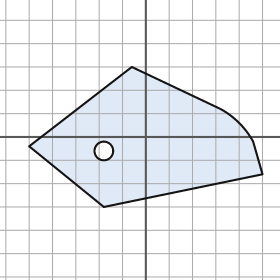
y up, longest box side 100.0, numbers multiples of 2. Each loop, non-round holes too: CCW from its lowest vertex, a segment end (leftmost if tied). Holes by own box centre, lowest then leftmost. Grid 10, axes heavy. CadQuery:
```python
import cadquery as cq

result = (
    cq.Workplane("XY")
    .moveTo(-18.0, -30.0)
    .lineTo(50.0, -16.0)
    .lineTo(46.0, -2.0)
    .threePointArc((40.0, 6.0), (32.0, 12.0))
    .lineTo(-6.0, 30.0)
    .lineTo(-50.0, -4.0)
    .close()
    .moveTo(-18.0, -6.0)
    .circle(4.0)
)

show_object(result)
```